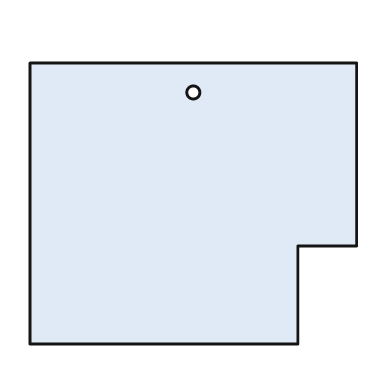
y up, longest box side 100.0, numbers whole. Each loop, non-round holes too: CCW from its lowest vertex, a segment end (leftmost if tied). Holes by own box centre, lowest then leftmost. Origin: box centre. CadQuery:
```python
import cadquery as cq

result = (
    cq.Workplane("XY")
    .moveTo(-50.0, -43.0)
    .lineTo(32.0, -43.0)
    .lineTo(32.0, -13.0)
    .lineTo(50.0, -13.0)
    .lineTo(50.0, 43.0)
    .lineTo(-50.0, 43.0)
    .close()
    .moveTo(0.0, 34.0)
    .circle(2.0)
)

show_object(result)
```